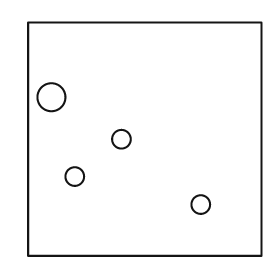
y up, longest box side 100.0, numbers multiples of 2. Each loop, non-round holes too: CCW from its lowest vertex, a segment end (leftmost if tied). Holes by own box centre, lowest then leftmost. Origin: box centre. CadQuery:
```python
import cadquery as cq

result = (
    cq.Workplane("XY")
    .moveTo(-50.0, -50.0)
    .lineTo(50.0, -50.0)
    .lineTo(50.0, 50.0)
    .lineTo(-50.0, 50.0)
    .close()
    .moveTo(24.0, -28.0)
    .circle(4.0)
    .moveTo(-30.0, -16.0)
    .circle(4.0)
    .moveTo(-10.0, 0.0)
    .circle(4.0)
    .moveTo(-40.0, 18.0)
    .circle(6.0)
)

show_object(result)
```